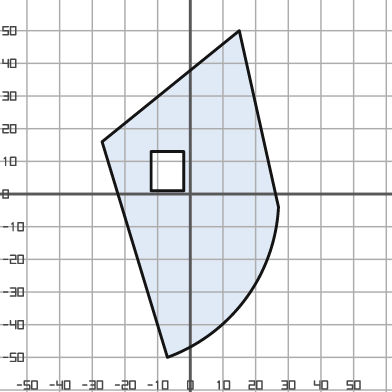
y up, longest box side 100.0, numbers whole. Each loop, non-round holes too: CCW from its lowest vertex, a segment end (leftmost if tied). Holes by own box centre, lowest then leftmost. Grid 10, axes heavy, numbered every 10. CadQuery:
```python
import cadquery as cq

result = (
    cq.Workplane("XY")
    .moveTo(-7.0, -50.0)
    .threePointArc((17.0, -32.0), (27.0, -4.0))
    .lineTo(15.0, 50.0)
    .lineTo(-27.0, 16.0)
    .close()
    .moveTo(-12.0, 1.0)
    .lineTo(-2.0, 1.0)
    .lineTo(-2.0, 13.0)
    .lineTo(-12.0, 13.0)
    .close()
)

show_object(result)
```